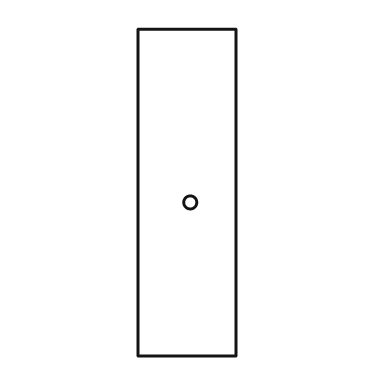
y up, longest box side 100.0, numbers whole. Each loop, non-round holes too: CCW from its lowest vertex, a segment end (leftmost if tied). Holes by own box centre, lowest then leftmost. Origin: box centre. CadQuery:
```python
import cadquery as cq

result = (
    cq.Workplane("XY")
    .moveTo(-15.0, -50.0)
    .lineTo(15.0, -50.0)
    .lineTo(15.0, 50.0)
    .lineTo(-15.0, 50.0)
    .close()
    .moveTo(1.0, -3.0)
    .circle(2.0)
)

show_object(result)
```